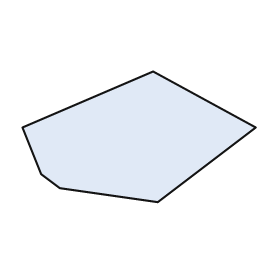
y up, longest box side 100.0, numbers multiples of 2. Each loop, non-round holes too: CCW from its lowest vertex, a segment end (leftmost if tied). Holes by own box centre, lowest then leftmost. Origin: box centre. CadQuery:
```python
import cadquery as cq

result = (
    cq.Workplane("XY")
    .moveTo(8.0, -28.0)
    .lineTo(50.0, 4.0)
    .lineTo(6.0, 28.0)
    .lineTo(-50.0, 4.0)
    .lineTo(-42.0, -16.0)
    .lineTo(-34.0, -22.0)
    .close()
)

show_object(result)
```